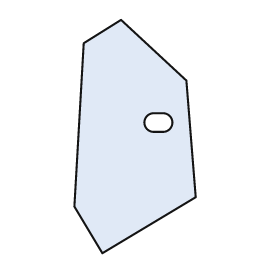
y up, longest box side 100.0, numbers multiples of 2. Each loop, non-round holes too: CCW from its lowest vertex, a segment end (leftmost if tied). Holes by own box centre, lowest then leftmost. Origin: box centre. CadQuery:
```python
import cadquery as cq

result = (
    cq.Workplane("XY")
    .moveTo(-14.0, -50.0)
    .lineTo(26.0, -26.0)
    .lineTo(22.0, 24.0)
    .lineTo(-6.0, 50.0)
    .lineTo(-22.0, 40.0)
    .lineTo(-26.0, -30.0)
    .close()
    .moveTo(8.0, 2.0)
    .lineTo(12.0, 2.0)
    .threePointArc((16.0, 6.0), (12.0, 10.0))
    .lineTo(8.0, 10.0)
    .threePointArc((4.0, 6.0), (8.0, 2.0))
    .close()
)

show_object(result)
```